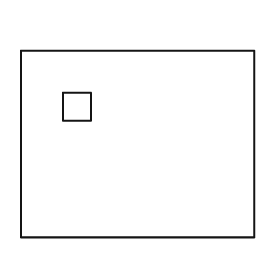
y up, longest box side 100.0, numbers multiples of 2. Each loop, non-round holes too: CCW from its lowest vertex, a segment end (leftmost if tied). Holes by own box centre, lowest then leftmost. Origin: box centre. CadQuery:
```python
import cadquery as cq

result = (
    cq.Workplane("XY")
    .moveTo(-50.0, -40.0)
    .lineTo(50.0, -40.0)
    .lineTo(50.0, 40.0)
    .lineTo(-50.0, 40.0)
    .close()
    .moveTo(-32.0, 10.0)
    .lineTo(-20.0, 10.0)
    .lineTo(-20.0, 22.0)
    .lineTo(-32.0, 22.0)
    .close()
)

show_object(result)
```